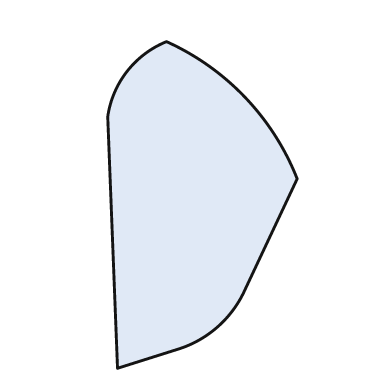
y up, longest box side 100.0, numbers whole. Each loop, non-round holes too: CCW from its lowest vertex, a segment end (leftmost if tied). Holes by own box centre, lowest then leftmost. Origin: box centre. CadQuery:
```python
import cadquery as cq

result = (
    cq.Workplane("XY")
    .moveTo(-26.0, -50.0)
    .lineTo(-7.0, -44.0)
    .threePointArc((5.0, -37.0), (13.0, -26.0))
    .lineTo(29.0, 8.0)
    .threePointArc((13.0, 33.0), (-11.0, 50.0))
    .threePointArc((-23.0, 41.0), (-29.0, 27.0))
    .close()
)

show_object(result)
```